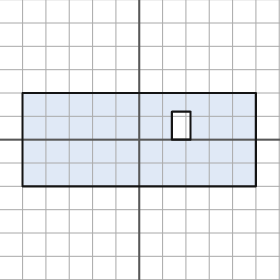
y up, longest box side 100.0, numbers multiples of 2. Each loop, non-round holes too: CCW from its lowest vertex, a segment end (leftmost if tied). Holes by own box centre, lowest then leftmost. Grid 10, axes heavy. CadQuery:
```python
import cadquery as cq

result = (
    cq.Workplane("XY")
    .moveTo(-50.0, -20.0)
    .lineTo(50.0, -20.0)
    .lineTo(50.0, 20.0)
    .lineTo(-50.0, 20.0)
    .close()
    .moveTo(14.0, 0.0)
    .lineTo(22.0, 0.0)
    .lineTo(22.0, 12.0)
    .lineTo(14.0, 12.0)
    .close()
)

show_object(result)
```